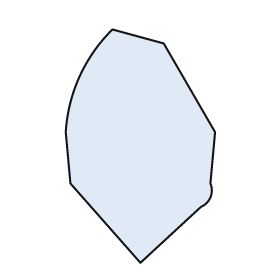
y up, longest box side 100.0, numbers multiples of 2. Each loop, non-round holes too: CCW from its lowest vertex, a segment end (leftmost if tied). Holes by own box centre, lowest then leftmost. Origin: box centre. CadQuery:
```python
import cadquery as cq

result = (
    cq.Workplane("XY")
    .moveTo(0.0, -50.0)
    .lineTo(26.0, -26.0)
    .threePointArc((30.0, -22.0), (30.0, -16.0))
    .lineTo(32.0, 6.0)
    .lineTo(10.0, 44.0)
    .lineTo(-12.0, 50.0)
    .threePointArc((-26.0, 30.0), (-32.0, 6.0))
    .lineTo(-30.0, -16.0)
    .close()
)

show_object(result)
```